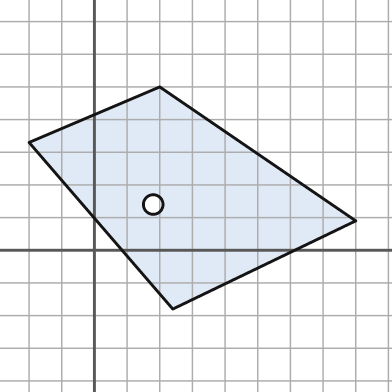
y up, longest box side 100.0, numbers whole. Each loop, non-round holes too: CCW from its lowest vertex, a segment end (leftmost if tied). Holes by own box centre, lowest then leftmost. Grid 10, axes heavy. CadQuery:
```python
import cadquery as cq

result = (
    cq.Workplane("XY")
    .moveTo(24.0, -18.0)
    .lineTo(80.0, 9.0)
    .lineTo(20.0, 50.0)
    .lineTo(-20.0, 33.0)
    .close()
    .moveTo(18.0, 14.0)
    .circle(3.0)
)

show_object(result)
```